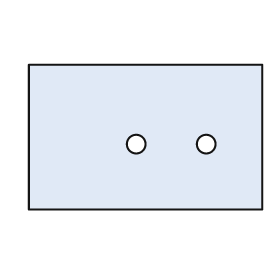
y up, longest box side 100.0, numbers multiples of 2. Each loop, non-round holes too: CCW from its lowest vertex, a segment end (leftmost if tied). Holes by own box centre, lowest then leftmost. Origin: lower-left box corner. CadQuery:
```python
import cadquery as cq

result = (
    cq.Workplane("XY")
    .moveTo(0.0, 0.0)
    .lineTo(100.0, 0.0)
    .lineTo(100.0, 62.0)
    .lineTo(0.0, 62.0)
    .close()
    .moveTo(46.0, 28.0)
    .circle(4.0)
    .moveTo(76.0, 28.0)
    .circle(4.0)
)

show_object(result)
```